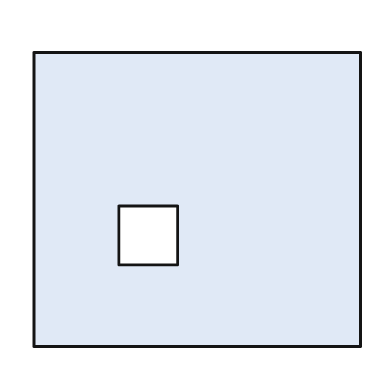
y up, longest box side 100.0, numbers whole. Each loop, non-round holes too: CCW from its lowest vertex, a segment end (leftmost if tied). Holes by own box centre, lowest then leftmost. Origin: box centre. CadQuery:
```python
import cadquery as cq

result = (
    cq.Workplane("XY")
    .moveTo(-50.0, -45.0)
    .lineTo(50.0, -45.0)
    .lineTo(50.0, 45.0)
    .lineTo(-50.0, 45.0)
    .close()
    .moveTo(-24.0, -20.0)
    .lineTo(-6.0, -20.0)
    .lineTo(-6.0, -2.0)
    .lineTo(-24.0, -2.0)
    .close()
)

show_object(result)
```